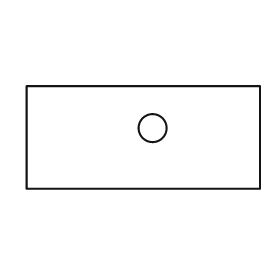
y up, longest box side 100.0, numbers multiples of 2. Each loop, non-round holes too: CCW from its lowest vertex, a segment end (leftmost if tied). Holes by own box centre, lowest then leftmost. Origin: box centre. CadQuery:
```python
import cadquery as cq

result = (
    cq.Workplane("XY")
    .moveTo(-50.0, -22.0)
    .lineTo(50.0, -22.0)
    .lineTo(50.0, 22.0)
    .lineTo(-50.0, 22.0)
    .close()
    .moveTo(4.0, 4.0)
    .circle(6.0)
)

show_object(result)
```